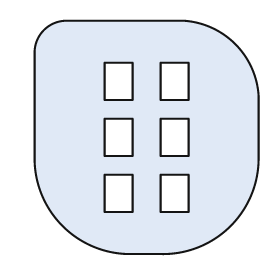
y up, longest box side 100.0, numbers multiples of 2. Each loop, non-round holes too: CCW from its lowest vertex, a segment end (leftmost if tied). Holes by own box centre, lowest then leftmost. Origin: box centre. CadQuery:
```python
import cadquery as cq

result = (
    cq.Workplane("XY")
    .moveTo(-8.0, -50.0)
    .lineTo(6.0, -50.0)
    .threePointArc((36.0, -38.0), (48.0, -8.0))
    .lineTo(48.0, 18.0)
    .threePointArc((38.0, 40.0), (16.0, 50.0))
    .lineTo(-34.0, 50.0)
    .threePointArc((-44.0, 46.0), (-48.0, 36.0))
    .lineTo(-48.0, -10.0)
    .threePointArc((-36.0, -38.0), (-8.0, -50.0))
    .close()
    .moveTo(-18.0, -32.0)
    .lineTo(-6.0, -32.0)
    .lineTo(-6.0, -16.0)
    .lineTo(-18.0, -16.0)
    .close()
    .moveTo(6.0, -32.0)
    .lineTo(18.0, -32.0)
    .lineTo(18.0, -16.0)
    .lineTo(6.0, -16.0)
    .close()
    .moveTo(-18.0, -8.0)
    .lineTo(-6.0, -8.0)
    .lineTo(-6.0, 8.0)
    .lineTo(-18.0, 8.0)
    .close()
    .moveTo(6.0, -8.0)
    .lineTo(18.0, -8.0)
    .lineTo(18.0, 8.0)
    .lineTo(6.0, 8.0)
    .close()
    .moveTo(-18.0, 16.0)
    .lineTo(-6.0, 16.0)
    .lineTo(-6.0, 32.0)
    .lineTo(-18.0, 32.0)
    .close()
    .moveTo(6.0, 16.0)
    .lineTo(18.0, 16.0)
    .lineTo(18.0, 32.0)
    .lineTo(6.0, 32.0)
    .close()
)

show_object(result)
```